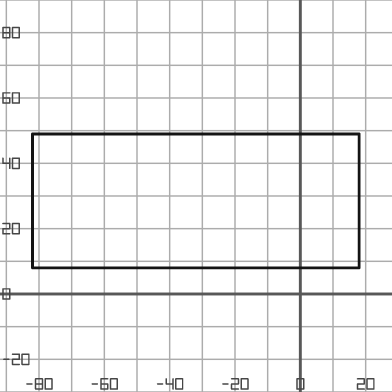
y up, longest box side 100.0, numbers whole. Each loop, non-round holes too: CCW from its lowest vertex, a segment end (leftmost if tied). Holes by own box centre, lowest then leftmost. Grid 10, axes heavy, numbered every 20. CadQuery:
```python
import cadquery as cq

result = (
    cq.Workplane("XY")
    .moveTo(-82.0, 8.0)
    .lineTo(18.0, 8.0)
    .lineTo(18.0, 49.0)
    .lineTo(-82.0, 49.0)
    .close()
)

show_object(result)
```